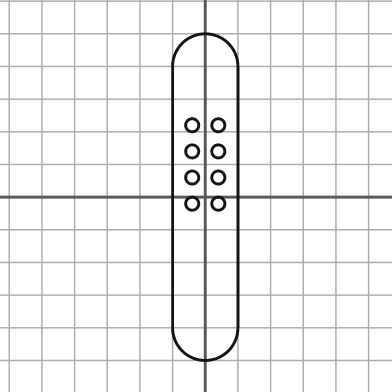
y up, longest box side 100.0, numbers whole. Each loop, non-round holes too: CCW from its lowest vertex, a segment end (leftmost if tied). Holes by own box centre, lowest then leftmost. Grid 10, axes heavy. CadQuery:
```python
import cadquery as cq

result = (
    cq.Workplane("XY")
    .moveTo(-10.0, -40.0)
    .threePointArc((0.0, -50.0), (10.0, -40.0))
    .lineTo(10.0, 40.0)
    .threePointArc((0.0, 50.0), (-10.0, 40.0))
    .close()
    .moveTo(-4.0, -2.0)
    .circle(2.0)
    .moveTo(4.0, -2.0)
    .circle(2.0)
    .moveTo(-4.0, 6.0)
    .circle(2.0)
    .moveTo(4.0, 6.0)
    .circle(2.0)
    .moveTo(-4.0, 14.0)
    .circle(2.0)
    .moveTo(4.0, 14.0)
    .circle(2.0)
    .moveTo(-4.0, 22.0)
    .circle(2.0)
    .moveTo(4.0, 22.0)
    .circle(2.0)
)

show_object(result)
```